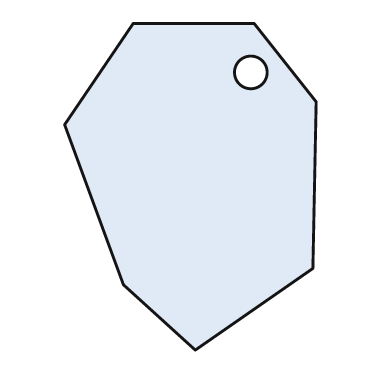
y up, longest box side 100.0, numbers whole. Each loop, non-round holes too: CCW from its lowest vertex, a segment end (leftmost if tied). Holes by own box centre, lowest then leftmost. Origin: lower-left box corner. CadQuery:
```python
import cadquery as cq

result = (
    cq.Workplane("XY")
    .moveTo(40.0, 0.0)
    .lineTo(76.0, 25.0)
    .lineTo(77.0, 76.0)
    .lineTo(58.0, 100.0)
    .lineTo(21.0, 100.0)
    .lineTo(0.0, 69.0)
    .lineTo(18.0, 20.0)
    .close()
    .moveTo(57.0, 85.0)
    .circle(5.0)
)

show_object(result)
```